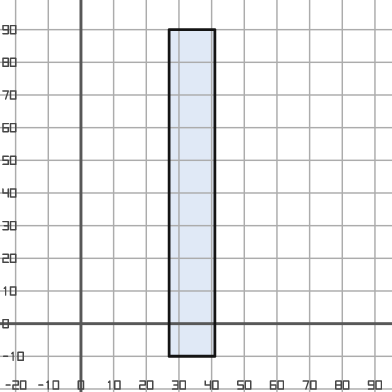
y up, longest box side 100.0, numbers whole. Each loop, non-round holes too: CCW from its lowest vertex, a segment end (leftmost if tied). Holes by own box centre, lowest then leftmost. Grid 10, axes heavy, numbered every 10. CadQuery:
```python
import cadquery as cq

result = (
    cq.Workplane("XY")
    .moveTo(27.0, -10.0)
    .lineTo(41.0, -10.0)
    .lineTo(41.0, 90.0)
    .lineTo(27.0, 90.0)
    .close()
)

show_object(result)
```